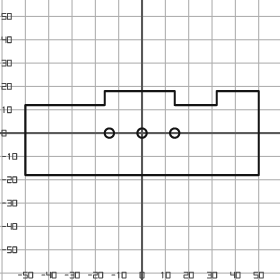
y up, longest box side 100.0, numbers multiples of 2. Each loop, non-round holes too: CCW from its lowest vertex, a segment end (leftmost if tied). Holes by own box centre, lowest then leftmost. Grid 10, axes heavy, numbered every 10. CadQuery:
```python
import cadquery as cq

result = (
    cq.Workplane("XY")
    .moveTo(-50.0, -18.0)
    .lineTo(50.0, -18.0)
    .lineTo(50.0, 18.0)
    .lineTo(32.0, 18.0)
    .lineTo(32.0, 12.0)
    .lineTo(14.0, 12.0)
    .lineTo(14.0, 18.0)
    .lineTo(-16.0, 18.0)
    .lineTo(-16.0, 12.0)
    .lineTo(-50.0, 12.0)
    .close()
    .moveTo(-14.0, 0.0)
    .circle(2.0)
    .moveTo(0.0, 0.0)
    .circle(2.0)
    .moveTo(14.0, 0.0)
    .circle(2.0)
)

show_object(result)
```